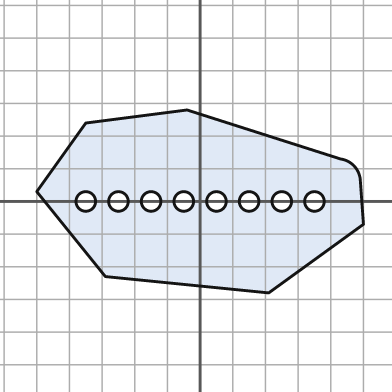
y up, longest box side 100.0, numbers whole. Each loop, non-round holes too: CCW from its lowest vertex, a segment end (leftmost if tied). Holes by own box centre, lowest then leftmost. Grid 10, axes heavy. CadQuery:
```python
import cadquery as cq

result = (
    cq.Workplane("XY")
    .moveTo(21.0, -28.0)
    .lineTo(50.0, -7.0)
    .lineTo(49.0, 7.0)
    .threePointArc((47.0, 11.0), (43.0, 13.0))
    .lineTo(-4.0, 28.0)
    .lineTo(-35.0, 24.0)
    .lineTo(-50.0, 3.0)
    .lineTo(-29.0, -23.0)
    .close()
    .moveTo(-35.0, 0.0)
    .circle(3.0)
    .moveTo(-25.0, 0.0)
    .circle(3.0)
    .moveTo(-15.0, 0.0)
    .circle(3.0)
    .moveTo(-5.0, 0.0)
    .circle(3.0)
    .moveTo(5.0, 0.0)
    .circle(3.0)
    .moveTo(15.0, 0.0)
    .circle(3.0)
    .moveTo(25.0, 0.0)
    .circle(3.0)
    .moveTo(35.0, 0.0)
    .circle(3.0)
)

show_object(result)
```